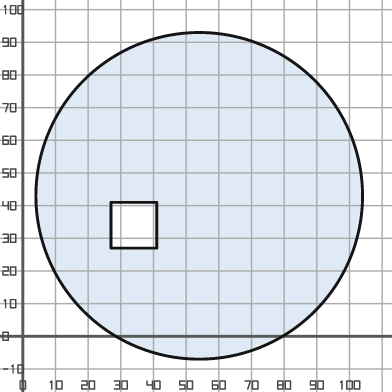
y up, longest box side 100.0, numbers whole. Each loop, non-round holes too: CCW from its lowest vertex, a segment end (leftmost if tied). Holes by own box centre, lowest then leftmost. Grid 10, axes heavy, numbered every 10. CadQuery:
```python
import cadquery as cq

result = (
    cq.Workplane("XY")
    .moveTo(54.0, 43.0)
    .circle(50.0)
    .moveTo(27.0, 27.0)
    .lineTo(41.0, 27.0)
    .lineTo(41.0, 41.0)
    .lineTo(27.0, 41.0)
    .close()
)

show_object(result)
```